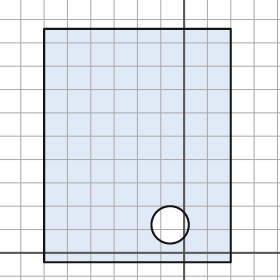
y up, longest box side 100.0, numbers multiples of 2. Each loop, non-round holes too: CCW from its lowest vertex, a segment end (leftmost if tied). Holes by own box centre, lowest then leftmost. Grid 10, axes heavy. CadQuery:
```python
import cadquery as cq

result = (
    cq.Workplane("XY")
    .moveTo(-60.0, -4.0)
    .lineTo(20.0, -4.0)
    .lineTo(20.0, 96.0)
    .lineTo(-60.0, 96.0)
    .close()
    .moveTo(-6.0, 12.0)
    .circle(8.0)
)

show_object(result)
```